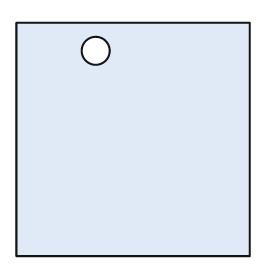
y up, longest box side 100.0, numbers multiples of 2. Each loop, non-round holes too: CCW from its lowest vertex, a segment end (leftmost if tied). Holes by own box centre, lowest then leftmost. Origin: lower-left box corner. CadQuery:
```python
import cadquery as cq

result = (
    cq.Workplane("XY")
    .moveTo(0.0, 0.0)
    .lineTo(100.0, 0.0)
    .lineTo(100.0, 100.0)
    .lineTo(0.0, 100.0)
    .close()
    .moveTo(34.0, 88.0)
    .circle(6.0)
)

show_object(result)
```